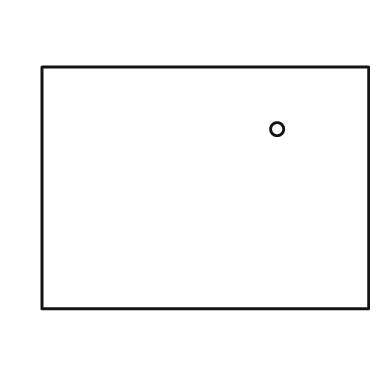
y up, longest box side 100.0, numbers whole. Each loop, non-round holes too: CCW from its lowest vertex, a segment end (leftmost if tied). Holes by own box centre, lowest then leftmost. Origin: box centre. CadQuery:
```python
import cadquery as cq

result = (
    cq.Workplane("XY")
    .moveTo(-50.0, -37.0)
    .lineTo(50.0, -37.0)
    .lineTo(50.0, 37.0)
    .lineTo(-50.0, 37.0)
    .close()
    .moveTo(22.0, 18.0)
    .circle(2.0)
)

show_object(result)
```